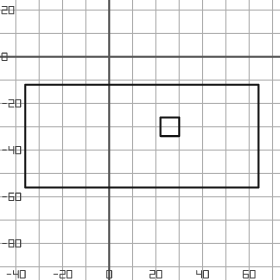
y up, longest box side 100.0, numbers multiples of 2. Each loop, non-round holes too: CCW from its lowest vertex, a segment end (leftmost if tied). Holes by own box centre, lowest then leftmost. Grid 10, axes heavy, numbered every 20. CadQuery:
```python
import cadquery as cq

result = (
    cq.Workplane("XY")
    .moveTo(-36.0, -56.0)
    .lineTo(64.0, -56.0)
    .lineTo(64.0, -12.0)
    .lineTo(-36.0, -12.0)
    .close()
    .moveTo(22.0, -34.0)
    .lineTo(30.0, -34.0)
    .lineTo(30.0, -26.0)
    .lineTo(22.0, -26.0)
    .close()
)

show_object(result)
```